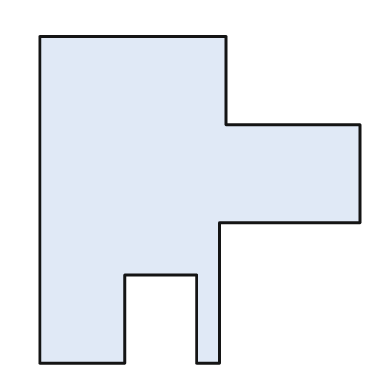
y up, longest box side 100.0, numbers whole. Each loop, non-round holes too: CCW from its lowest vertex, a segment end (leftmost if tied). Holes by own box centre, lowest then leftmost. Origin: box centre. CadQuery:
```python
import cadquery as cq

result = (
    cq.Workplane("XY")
    .moveTo(-49.0, -50.0)
    .lineTo(-23.0, -50.0)
    .lineTo(-23.0, -23.0)
    .lineTo(-1.0, -23.0)
    .lineTo(-1.0, -50.0)
    .lineTo(6.0, -50.0)
    .lineTo(6.0, -7.0)
    .lineTo(49.0, -7.0)
    .lineTo(49.0, 23.0)
    .lineTo(8.0, 23.0)
    .lineTo(8.0, 50.0)
    .lineTo(-49.0, 50.0)
    .close()
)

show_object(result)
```